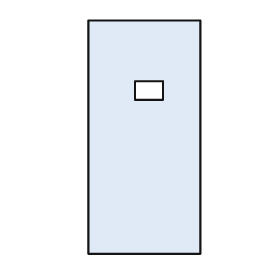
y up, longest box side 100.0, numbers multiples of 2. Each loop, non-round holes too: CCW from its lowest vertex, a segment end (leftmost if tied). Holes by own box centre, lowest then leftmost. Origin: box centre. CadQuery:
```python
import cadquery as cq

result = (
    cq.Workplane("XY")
    .moveTo(-24.0, -50.0)
    .lineTo(24.0, -50.0)
    .lineTo(24.0, 50.0)
    .lineTo(-24.0, 50.0)
    .close()
    .moveTo(-4.0, 16.0)
    .lineTo(8.0, 16.0)
    .lineTo(8.0, 24.0)
    .lineTo(-4.0, 24.0)
    .close()
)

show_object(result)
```